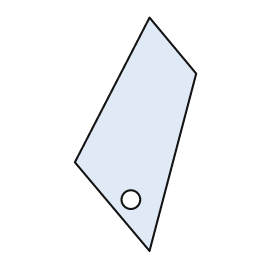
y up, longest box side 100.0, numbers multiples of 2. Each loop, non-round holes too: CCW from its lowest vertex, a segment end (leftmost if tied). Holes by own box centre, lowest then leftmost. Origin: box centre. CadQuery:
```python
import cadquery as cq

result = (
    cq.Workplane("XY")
    .moveTo(6.0, -50.0)
    .lineTo(26.0, 26.0)
    .lineTo(6.0, 50.0)
    .lineTo(-26.0, -12.0)
    .close()
    .moveTo(-2.0, -28.0)
    .circle(4.0)
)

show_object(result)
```